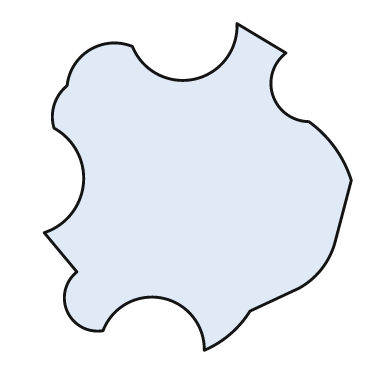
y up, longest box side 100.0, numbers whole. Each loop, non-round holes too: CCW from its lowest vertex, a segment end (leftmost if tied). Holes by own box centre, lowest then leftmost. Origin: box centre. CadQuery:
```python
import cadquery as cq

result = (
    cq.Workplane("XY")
    .moveTo(2.0, -50.0)
    .threePointArc((10.0, -45.0), (16.0, -38.0))
    .lineTo(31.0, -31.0)
    .threePointArc((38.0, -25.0), (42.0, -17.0))
    .lineTo(47.0, 2.0)
    .threePointArc((42.0, 12.0), (34.0, 20.0))
    .threePointArc((23.0, 28.0), (27.0, 41.0))
    .lineTo(12.0, 50.0)
    .threePointArc((-1.0, 33.0), (-20.0, 43.0))
    .threePointArc((-33.0, 42.0), (-40.0, 31.0))
    .threePointArc((-44.0, 25.0), (-44.0, 18.0))
    .threePointArc((-35.0, 1.0), (-47.0, -14.0))
    .lineTo(-37.0, -26.0)
    .threePointArc((-40.0, -38.0), (-29.0, -44.0))
    .threePointArc((-11.0, -34.0), (2.0, -50.0))
    .close()
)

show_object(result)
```